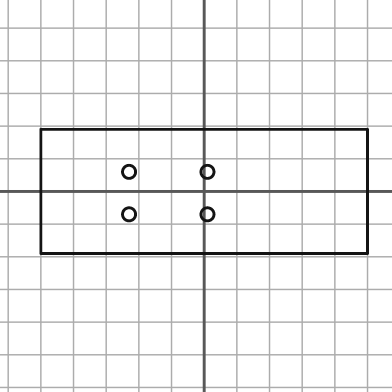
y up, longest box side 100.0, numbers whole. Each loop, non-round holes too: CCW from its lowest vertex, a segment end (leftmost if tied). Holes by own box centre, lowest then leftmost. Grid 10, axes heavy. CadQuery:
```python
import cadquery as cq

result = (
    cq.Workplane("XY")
    .moveTo(-50.0, -19.0)
    .lineTo(50.0, -19.0)
    .lineTo(50.0, 19.0)
    .lineTo(-50.0, 19.0)
    .close()
    .moveTo(-23.0, -7.0)
    .circle(2.0)
    .moveTo(1.0, -7.0)
    .circle(2.0)
    .moveTo(-23.0, 6.0)
    .circle(2.0)
    .moveTo(1.0, 6.0)
    .circle(2.0)
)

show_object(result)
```